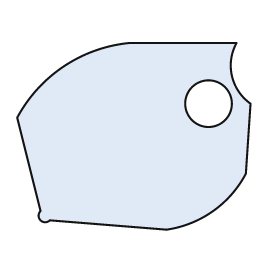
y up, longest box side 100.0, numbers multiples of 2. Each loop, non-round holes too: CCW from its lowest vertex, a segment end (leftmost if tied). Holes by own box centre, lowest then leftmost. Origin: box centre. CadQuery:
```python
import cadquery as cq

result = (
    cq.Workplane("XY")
    .moveTo(14.0, -40.0)
    .threePointArc((34.0, -32.0), (48.0, -16.0))
    .lineTo(50.0, 14.0)
    .threePointArc((42.0, 26.0), (44.0, 40.0))
    .lineTo(-2.0, 40.0)
    .threePointArc((-30.0, 30.0), (-50.0, 8.0))
    .lineTo(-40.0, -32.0)
    .threePointArc((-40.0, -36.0), (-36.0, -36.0))
    .close()
    .moveTo(32.0, 14.0)
    .circle(10.0)
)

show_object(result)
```